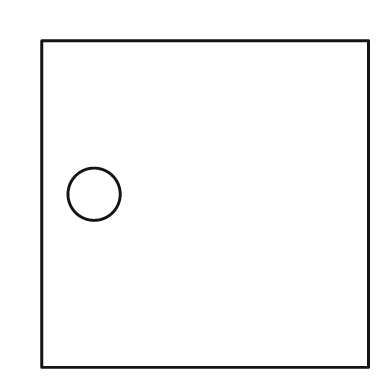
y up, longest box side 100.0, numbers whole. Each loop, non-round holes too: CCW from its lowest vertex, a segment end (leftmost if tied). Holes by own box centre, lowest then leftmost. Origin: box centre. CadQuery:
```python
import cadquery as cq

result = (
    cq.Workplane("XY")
    .moveTo(-50.0, -50.0)
    .lineTo(50.0, -50.0)
    .lineTo(50.0, 50.0)
    .lineTo(-50.0, 50.0)
    .close()
    .moveTo(-34.0, 3.0)
    .circle(8.0)
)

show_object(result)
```